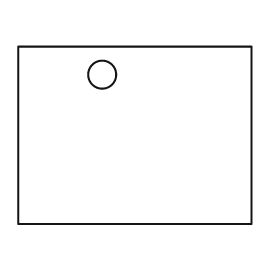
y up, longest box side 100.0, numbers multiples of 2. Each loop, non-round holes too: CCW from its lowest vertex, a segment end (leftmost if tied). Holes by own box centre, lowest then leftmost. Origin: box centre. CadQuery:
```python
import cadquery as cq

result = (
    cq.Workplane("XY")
    .moveTo(-50.0, -38.0)
    .lineTo(50.0, -38.0)
    .lineTo(50.0, 38.0)
    .lineTo(-50.0, 38.0)
    .close()
    .moveTo(-14.0, 26.0)
    .circle(6.0)
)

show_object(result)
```